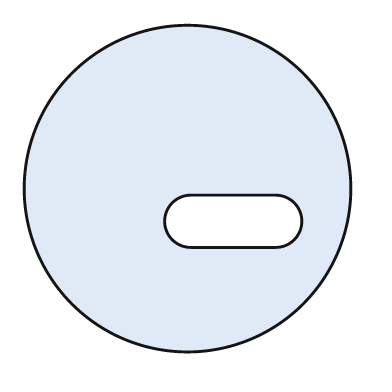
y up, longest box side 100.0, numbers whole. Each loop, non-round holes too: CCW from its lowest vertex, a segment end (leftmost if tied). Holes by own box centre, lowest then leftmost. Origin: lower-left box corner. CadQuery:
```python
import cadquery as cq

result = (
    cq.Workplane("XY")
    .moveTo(50.0, 50.0)
    .circle(50.0)
    .moveTo(51.0, 32.0)
    .lineTo(77.0, 32.0)
    .threePointArc((85.0, 40.0), (77.0, 48.0))
    .lineTo(51.0, 48.0)
    .threePointArc((43.0, 40.0), (51.0, 32.0))
    .close()
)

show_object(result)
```